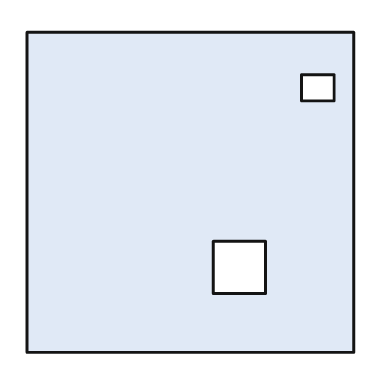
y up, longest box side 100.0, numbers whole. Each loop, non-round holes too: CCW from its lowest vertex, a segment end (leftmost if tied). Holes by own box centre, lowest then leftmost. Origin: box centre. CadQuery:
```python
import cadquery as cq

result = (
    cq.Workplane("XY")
    .moveTo(-50.0, -49.0)
    .lineTo(50.0, -49.0)
    .lineTo(50.0, 49.0)
    .lineTo(-50.0, 49.0)
    .close()
    .moveTo(7.0, -31.0)
    .lineTo(23.0, -31.0)
    .lineTo(23.0, -15.0)
    .lineTo(7.0, -15.0)
    .close()
    .moveTo(34.0, 28.0)
    .lineTo(44.0, 28.0)
    .lineTo(44.0, 36.0)
    .lineTo(34.0, 36.0)
    .close()
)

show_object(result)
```